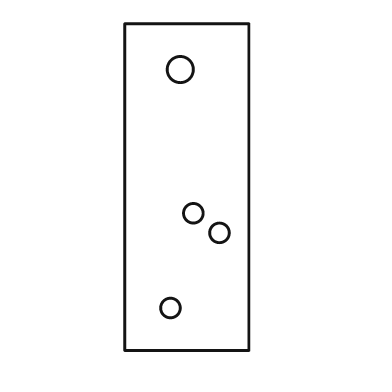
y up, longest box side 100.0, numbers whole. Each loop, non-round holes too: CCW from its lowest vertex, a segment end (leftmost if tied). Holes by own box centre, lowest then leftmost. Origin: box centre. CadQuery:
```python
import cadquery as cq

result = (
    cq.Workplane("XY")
    .moveTo(-19.0, -50.0)
    .lineTo(19.0, -50.0)
    .lineTo(19.0, 50.0)
    .lineTo(-19.0, 50.0)
    .close()
    .moveTo(-5.0, -37.0)
    .circle(3.0)
    .moveTo(10.0, -14.0)
    .circle(3.0)
    .moveTo(2.0, -8.0)
    .circle(3.0)
    .moveTo(-2.0, 36.0)
    .circle(4.0)
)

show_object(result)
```